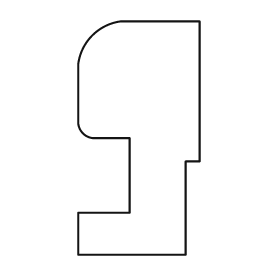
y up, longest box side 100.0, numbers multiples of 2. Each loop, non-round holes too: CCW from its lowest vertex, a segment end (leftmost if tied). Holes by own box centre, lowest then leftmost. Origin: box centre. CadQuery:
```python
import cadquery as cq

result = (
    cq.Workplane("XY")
    .moveTo(-26.0, -50.0)
    .lineTo(20.0, -50.0)
    .lineTo(20.0, -10.0)
    .lineTo(26.0, -10.0)
    .lineTo(26.0, 50.0)
    .lineTo(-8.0, 50.0)
    .threePointArc((-20.0, 44.0), (-26.0, 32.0))
    .lineTo(-26.0, 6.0)
    .threePointArc((-24.0, 2.0), (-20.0, 0.0))
    .lineTo(-4.0, 0.0)
    .lineTo(-4.0, -32.0)
    .lineTo(-26.0, -32.0)
    .close()
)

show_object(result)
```